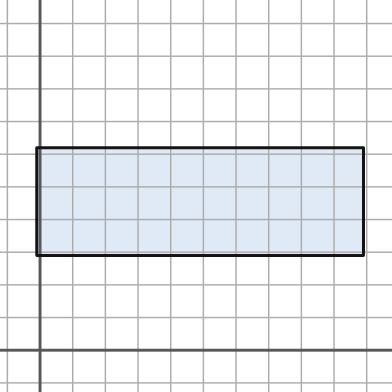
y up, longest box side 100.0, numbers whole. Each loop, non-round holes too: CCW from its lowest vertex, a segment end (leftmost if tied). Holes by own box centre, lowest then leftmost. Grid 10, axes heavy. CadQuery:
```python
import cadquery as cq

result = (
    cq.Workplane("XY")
    .moveTo(-1.0, 29.0)
    .lineTo(99.0, 29.0)
    .lineTo(99.0, 62.0)
    .lineTo(-1.0, 62.0)
    .close()
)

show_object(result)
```